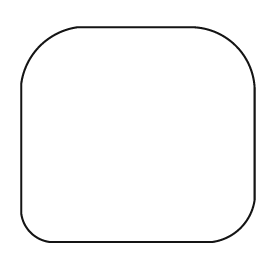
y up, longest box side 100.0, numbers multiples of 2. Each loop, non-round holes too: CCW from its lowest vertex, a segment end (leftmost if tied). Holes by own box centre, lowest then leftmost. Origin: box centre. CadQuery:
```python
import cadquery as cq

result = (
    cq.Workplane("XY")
    .moveTo(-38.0, -46.0)
    .lineTo(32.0, -46.0)
    .threePointArc((44.0, -40.0), (50.0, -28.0))
    .lineTo(50.0, 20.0)
    .threePointArc((42.0, 38.0), (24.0, 46.0))
    .lineTo(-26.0, 46.0)
    .threePointArc((-42.0, 38.0), (-50.0, 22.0))
    .lineTo(-50.0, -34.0)
    .threePointArc((-46.0, -42.0), (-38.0, -46.0))
    .close()
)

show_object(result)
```